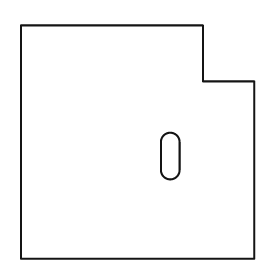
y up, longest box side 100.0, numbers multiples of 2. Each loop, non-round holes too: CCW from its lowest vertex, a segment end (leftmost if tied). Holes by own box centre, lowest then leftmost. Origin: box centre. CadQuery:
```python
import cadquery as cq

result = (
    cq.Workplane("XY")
    .moveTo(-50.0, -50.0)
    .lineTo(50.0, -50.0)
    .lineTo(50.0, 26.0)
    .lineTo(28.0, 26.0)
    .lineTo(28.0, 50.0)
    .lineTo(-50.0, 50.0)
    .close()
    .moveTo(10.0, -12.0)
    .threePointArc((14.0, -16.0), (18.0, -12.0))
    .lineTo(18.0, 0.0)
    .threePointArc((14.0, 4.0), (10.0, 0.0))
    .close()
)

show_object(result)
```